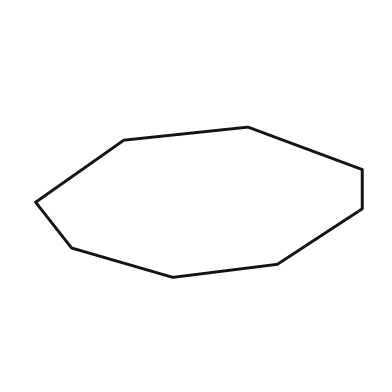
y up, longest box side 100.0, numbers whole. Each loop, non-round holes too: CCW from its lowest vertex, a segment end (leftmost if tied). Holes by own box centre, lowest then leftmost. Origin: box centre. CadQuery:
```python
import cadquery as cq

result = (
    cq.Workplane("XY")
    .moveTo(-8.0, -23.0)
    .lineTo(24.0, -19.0)
    .lineTo(50.0, -2.0)
    .lineTo(50.0, 10.0)
    .lineTo(15.0, 23.0)
    .lineTo(-23.0, 19.0)
    .lineTo(-50.0, 0.0)
    .lineTo(-39.0, -14.0)
    .close()
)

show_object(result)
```